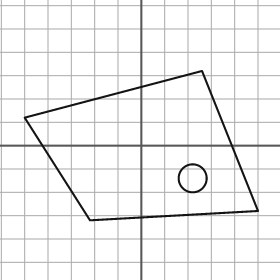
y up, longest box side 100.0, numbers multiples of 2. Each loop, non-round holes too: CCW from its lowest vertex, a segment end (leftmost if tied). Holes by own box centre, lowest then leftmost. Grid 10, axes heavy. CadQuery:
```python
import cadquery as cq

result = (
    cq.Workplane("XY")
    .moveTo(-22.0, -32.0)
    .lineTo(50.0, -28.0)
    .lineTo(26.0, 32.0)
    .lineTo(-50.0, 12.0)
    .close()
    .moveTo(22.0, -14.0)
    .circle(6.0)
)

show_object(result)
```